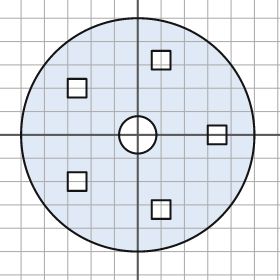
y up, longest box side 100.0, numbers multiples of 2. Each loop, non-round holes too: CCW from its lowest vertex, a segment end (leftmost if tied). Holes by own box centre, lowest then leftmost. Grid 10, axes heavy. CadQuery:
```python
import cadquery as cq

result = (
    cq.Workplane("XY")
    .moveTo(0.0, 0.0)
    .circle(50.0)
    .moveTo(6.0, -36.0)
    .lineTo(14.0, -36.0)
    .lineTo(14.0, -28.0)
    .lineTo(6.0, -28.0)
    .close()
    .moveTo(-30.0, -24.0)
    .lineTo(-22.0, -24.0)
    .lineTo(-22.0, -16.0)
    .lineTo(-30.0, -16.0)
    .close()
    .moveTo(0.0, 0.0)
    .circle(8.0)
    .moveTo(30.0, -4.0)
    .lineTo(38.0, -4.0)
    .lineTo(38.0, 4.0)
    .lineTo(30.0, 4.0)
    .close()
    .moveTo(-30.0, 16.0)
    .lineTo(-22.0, 16.0)
    .lineTo(-22.0, 24.0)
    .lineTo(-30.0, 24.0)
    .close()
    .moveTo(6.0, 28.0)
    .lineTo(14.0, 28.0)
    .lineTo(14.0, 36.0)
    .lineTo(6.0, 36.0)
    .close()
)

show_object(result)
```